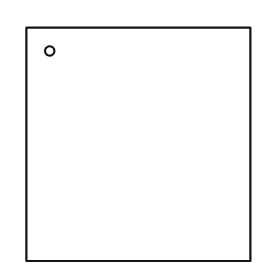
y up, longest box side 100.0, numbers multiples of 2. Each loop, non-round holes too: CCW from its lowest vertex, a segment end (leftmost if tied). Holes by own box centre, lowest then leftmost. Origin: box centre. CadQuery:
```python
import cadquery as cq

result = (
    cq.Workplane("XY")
    .moveTo(-48.0, -50.0)
    .lineTo(48.0, -50.0)
    .lineTo(48.0, 50.0)
    .lineTo(-48.0, 50.0)
    .close()
    .moveTo(-38.0, 40.0)
    .circle(2.0)
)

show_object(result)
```